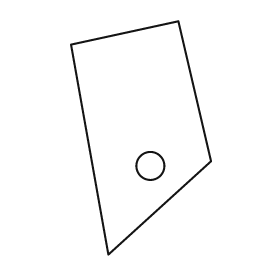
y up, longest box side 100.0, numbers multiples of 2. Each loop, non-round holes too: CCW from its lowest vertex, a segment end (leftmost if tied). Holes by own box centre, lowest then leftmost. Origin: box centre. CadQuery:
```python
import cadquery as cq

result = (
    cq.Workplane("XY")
    .moveTo(-14.0, -50.0)
    .lineTo(30.0, -10.0)
    .lineTo(16.0, 50.0)
    .lineTo(-30.0, 40.0)
    .close()
    .moveTo(4.0, -12.0)
    .circle(6.0)
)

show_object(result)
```